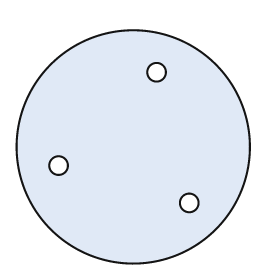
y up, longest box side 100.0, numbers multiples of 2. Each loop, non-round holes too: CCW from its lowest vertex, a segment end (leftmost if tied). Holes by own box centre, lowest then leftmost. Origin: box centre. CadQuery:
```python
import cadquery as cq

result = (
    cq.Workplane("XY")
    .moveTo(0.0, 0.0)
    .circle(50.0)
    .moveTo(24.0, -24.0)
    .circle(4.0)
    .moveTo(-32.0, -8.0)
    .circle(4.0)
    .moveTo(10.0, 32.0)
    .circle(4.0)
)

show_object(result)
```